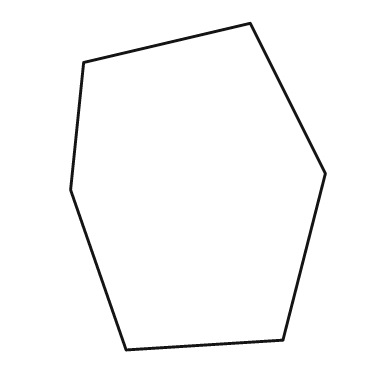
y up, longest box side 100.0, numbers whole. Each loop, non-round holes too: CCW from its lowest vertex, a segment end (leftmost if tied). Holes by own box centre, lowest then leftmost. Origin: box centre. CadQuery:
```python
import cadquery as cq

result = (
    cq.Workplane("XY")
    .moveTo(-22.0, -50.0)
    .lineTo(26.0, -47.0)
    .lineTo(39.0, 4.0)
    .lineTo(16.0, 50.0)
    .lineTo(-35.0, 38.0)
    .lineTo(-39.0, -1.0)
    .close()
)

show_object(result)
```